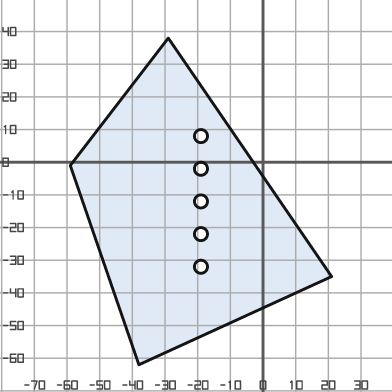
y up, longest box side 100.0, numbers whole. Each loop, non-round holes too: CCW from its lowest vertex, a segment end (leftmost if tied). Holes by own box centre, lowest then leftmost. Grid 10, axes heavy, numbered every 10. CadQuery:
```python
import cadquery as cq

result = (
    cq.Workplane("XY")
    .moveTo(-38.0, -62.0)
    .lineTo(21.0, -35.0)
    .lineTo(-29.0, 38.0)
    .lineTo(-59.0, -1.0)
    .close()
    .moveTo(-19.0, -32.0)
    .circle(2.0)
    .moveTo(-19.0, -22.0)
    .circle(2.0)
    .moveTo(-19.0, -12.0)
    .circle(2.0)
    .moveTo(-19.0, -2.0)
    .circle(2.0)
    .moveTo(-19.0, 8.0)
    .circle(2.0)
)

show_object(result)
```